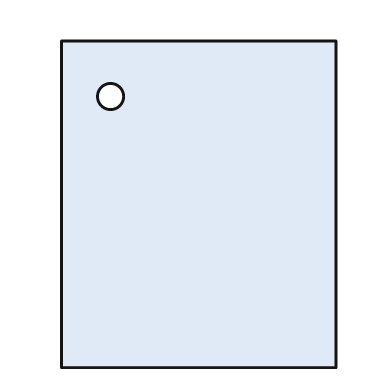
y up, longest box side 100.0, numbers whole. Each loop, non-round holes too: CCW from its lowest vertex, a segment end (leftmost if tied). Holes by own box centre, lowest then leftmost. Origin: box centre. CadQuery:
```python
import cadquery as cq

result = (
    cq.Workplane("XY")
    .moveTo(-42.0, -50.0)
    .lineTo(42.0, -50.0)
    .lineTo(42.0, 50.0)
    .lineTo(-42.0, 50.0)
    .close()
    .moveTo(-27.0, 33.0)
    .circle(4.0)
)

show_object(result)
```